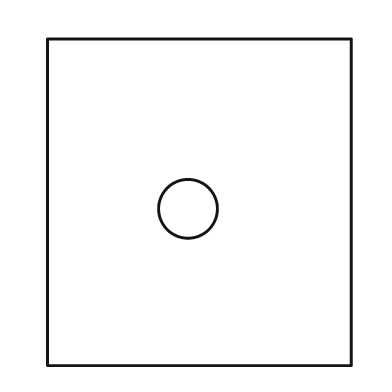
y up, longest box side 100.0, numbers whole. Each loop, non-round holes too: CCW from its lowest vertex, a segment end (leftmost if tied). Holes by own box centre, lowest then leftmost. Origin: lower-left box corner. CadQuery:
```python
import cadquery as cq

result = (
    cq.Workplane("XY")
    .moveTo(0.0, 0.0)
    .lineTo(93.0, 0.0)
    .lineTo(93.0, 100.0)
    .lineTo(0.0, 100.0)
    .close()
    .moveTo(43.0, 48.0)
    .circle(9.0)
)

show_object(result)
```